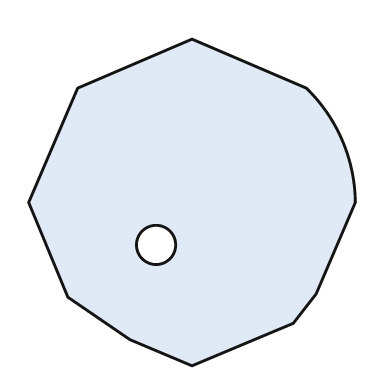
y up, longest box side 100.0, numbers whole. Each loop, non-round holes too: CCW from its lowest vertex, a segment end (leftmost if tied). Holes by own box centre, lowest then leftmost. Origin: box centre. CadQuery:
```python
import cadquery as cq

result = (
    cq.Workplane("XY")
    .moveTo(0.0, -50.0)
    .lineTo(31.0, -37.0)
    .lineTo(38.0, -28.0)
    .lineTo(50.0, 0.0)
    .threePointArc((46.0, 19.0), (35.0, 35.0))
    .lineTo(0.0, 50.0)
    .lineTo(-35.0, 35.0)
    .lineTo(-50.0, 0.0)
    .lineTo(-38.0, -29.0)
    .lineTo(-19.0, -42.0)
    .close()
    .moveTo(-11.0, -13.0)
    .circle(6.0)
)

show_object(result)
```